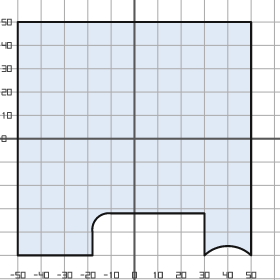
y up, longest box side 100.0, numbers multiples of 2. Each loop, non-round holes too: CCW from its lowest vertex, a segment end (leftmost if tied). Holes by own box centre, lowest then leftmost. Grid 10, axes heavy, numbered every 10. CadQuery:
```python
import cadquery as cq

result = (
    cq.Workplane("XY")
    .moveTo(-50.0, -50.0)
    .lineTo(-18.0, -50.0)
    .lineTo(-18.0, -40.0)
    .threePointArc((-16.0, -34.0), (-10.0, -32.0))
    .lineTo(30.0, -32.0)
    .lineTo(30.0, -50.0)
    .threePointArc((40.0, -46.0), (50.0, -50.0))
    .lineTo(50.0, 50.0)
    .lineTo(-50.0, 50.0)
    .close()
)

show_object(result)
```